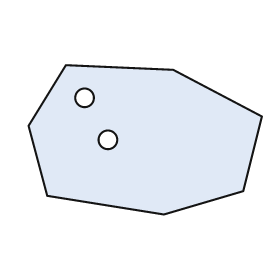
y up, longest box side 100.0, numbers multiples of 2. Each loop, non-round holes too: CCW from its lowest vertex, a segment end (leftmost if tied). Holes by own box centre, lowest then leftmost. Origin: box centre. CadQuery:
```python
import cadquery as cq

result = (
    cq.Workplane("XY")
    .moveTo(8.0, -32.0)
    .lineTo(42.0, -22.0)
    .lineTo(50.0, 10.0)
    .lineTo(12.0, 30.0)
    .lineTo(-34.0, 32.0)
    .lineTo(-50.0, 6.0)
    .lineTo(-42.0, -24.0)
    .close()
    .moveTo(-16.0, 0.0)
    .circle(4.0)
    .moveTo(-26.0, 18.0)
    .circle(4.0)
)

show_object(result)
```